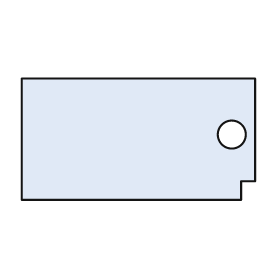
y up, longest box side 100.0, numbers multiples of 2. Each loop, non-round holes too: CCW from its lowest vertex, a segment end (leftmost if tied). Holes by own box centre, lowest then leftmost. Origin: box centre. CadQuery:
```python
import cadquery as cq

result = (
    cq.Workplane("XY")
    .moveTo(-50.0, -26.0)
    .lineTo(44.0, -26.0)
    .lineTo(44.0, -18.0)
    .lineTo(50.0, -18.0)
    .lineTo(50.0, 26.0)
    .lineTo(-50.0, 26.0)
    .close()
    .moveTo(40.0, 2.0)
    .circle(6.0)
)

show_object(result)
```